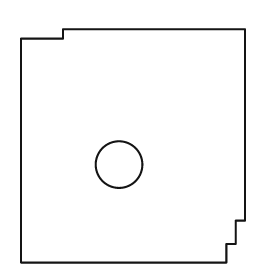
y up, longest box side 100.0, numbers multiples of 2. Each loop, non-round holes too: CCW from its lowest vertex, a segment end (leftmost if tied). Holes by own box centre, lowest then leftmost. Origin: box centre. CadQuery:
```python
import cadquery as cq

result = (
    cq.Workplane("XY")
    .moveTo(-48.0, -50.0)
    .lineTo(40.0, -50.0)
    .lineTo(40.0, -42.0)
    .lineTo(44.0, -42.0)
    .lineTo(44.0, -32.0)
    .lineTo(48.0, -32.0)
    .lineTo(48.0, 50.0)
    .lineTo(-30.0, 50.0)
    .lineTo(-30.0, 46.0)
    .lineTo(-48.0, 46.0)
    .close()
    .moveTo(-6.0, -8.0)
    .circle(10.0)
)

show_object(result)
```